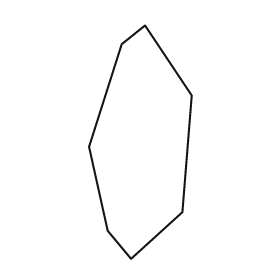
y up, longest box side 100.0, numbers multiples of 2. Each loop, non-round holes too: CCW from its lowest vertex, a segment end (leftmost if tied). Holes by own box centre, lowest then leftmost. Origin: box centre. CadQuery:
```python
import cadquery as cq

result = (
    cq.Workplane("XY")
    .moveTo(-4.0, -50.0)
    .lineTo(18.0, -30.0)
    .lineTo(22.0, 20.0)
    .lineTo(2.0, 50.0)
    .lineTo(-8.0, 42.0)
    .lineTo(-22.0, -2.0)
    .lineTo(-14.0, -38.0)
    .close()
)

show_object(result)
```